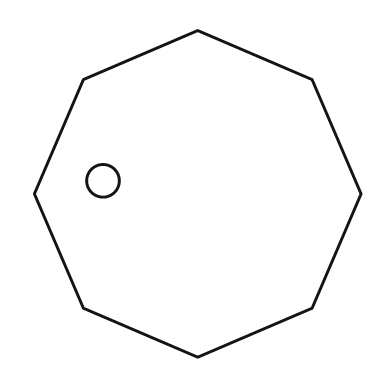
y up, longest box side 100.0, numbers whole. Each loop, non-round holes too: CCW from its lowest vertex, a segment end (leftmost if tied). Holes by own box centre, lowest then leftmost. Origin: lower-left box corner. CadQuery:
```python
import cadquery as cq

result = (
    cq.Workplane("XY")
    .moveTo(50.0, 0.0)
    .lineTo(85.0, 15.0)
    .lineTo(100.0, 50.0)
    .lineTo(85.0, 85.0)
    .lineTo(50.0, 100.0)
    .lineTo(15.0, 85.0)
    .lineTo(0.0, 50.0)
    .lineTo(15.0, 15.0)
    .close()
    .moveTo(21.0, 54.0)
    .circle(5.0)
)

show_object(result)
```